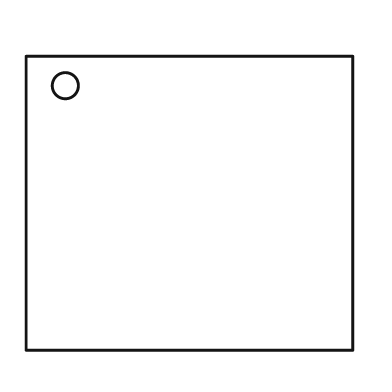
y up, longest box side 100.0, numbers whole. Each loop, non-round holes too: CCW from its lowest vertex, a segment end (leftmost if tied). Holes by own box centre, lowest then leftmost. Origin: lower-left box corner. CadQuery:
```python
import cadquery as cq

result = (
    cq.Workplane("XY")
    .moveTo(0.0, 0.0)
    .lineTo(100.0, 0.0)
    .lineTo(100.0, 90.0)
    .lineTo(0.0, 90.0)
    .close()
    .moveTo(12.0, 81.0)
    .circle(4.0)
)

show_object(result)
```